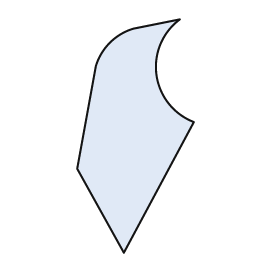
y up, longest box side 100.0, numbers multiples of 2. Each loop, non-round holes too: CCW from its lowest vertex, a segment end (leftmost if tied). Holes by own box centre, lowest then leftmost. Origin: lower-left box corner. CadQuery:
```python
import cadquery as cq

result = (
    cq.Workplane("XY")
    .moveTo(20.0, 0.0)
    .lineTo(50.0, 56.0)
    .threePointArc((34.0, 76.0), (44.0, 100.0))
    .lineTo(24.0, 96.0)
    .threePointArc((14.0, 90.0), (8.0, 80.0))
    .lineTo(0.0, 36.0)
    .close()
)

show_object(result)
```